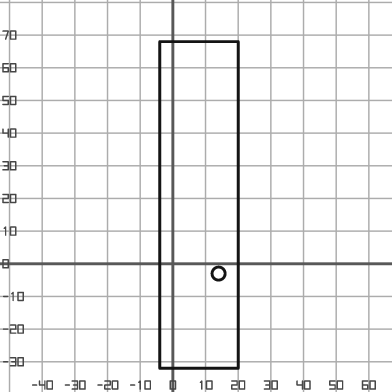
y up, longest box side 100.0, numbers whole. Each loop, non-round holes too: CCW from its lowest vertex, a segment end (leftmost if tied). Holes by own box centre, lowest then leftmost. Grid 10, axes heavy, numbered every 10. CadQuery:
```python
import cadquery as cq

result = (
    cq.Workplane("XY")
    .moveTo(-4.0, -32.0)
    .lineTo(20.0, -32.0)
    .lineTo(20.0, 68.0)
    .lineTo(-4.0, 68.0)
    .close()
    .moveTo(14.0, -3.0)
    .circle(2.0)
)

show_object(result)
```